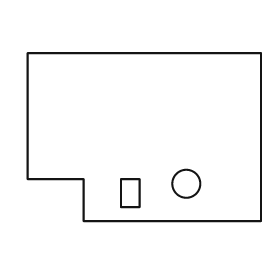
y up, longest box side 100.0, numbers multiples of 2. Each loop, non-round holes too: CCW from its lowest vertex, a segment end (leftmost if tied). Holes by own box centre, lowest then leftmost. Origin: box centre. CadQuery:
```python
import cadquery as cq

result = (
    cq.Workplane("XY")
    .moveTo(-26.0, -36.0)
    .lineTo(50.0, -36.0)
    .lineTo(50.0, 36.0)
    .lineTo(-50.0, 36.0)
    .lineTo(-50.0, -18.0)
    .lineTo(-26.0, -18.0)
    .close()
    .moveTo(-10.0, -30.0)
    .lineTo(-2.0, -30.0)
    .lineTo(-2.0, -18.0)
    .lineTo(-10.0, -18.0)
    .close()
    .moveTo(18.0, -20.0)
    .circle(6.0)
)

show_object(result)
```